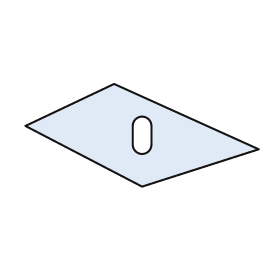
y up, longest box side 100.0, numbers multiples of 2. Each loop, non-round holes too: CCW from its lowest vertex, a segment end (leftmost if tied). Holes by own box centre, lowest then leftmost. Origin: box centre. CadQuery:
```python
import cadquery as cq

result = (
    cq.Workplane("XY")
    .moveTo(0.0, -22.0)
    .lineTo(50.0, -6.0)
    .lineTo(-12.0, 22.0)
    .lineTo(-50.0, 4.0)
    .close()
    .moveTo(-4.0, -4.0)
    .threePointArc((0.0, -8.0), (4.0, -4.0))
    .lineTo(4.0, 4.0)
    .threePointArc((0.0, 8.0), (-4.0, 4.0))
    .close()
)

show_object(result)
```